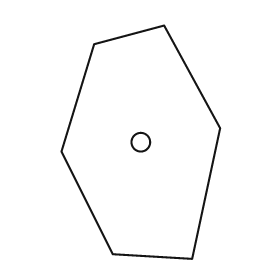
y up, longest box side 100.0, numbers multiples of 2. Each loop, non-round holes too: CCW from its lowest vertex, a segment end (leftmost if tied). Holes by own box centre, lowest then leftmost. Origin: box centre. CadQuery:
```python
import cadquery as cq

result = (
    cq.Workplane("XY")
    .moveTo(22.0, -50.0)
    .lineTo(34.0, 6.0)
    .lineTo(10.0, 50.0)
    .lineTo(-20.0, 42.0)
    .lineTo(-34.0, -4.0)
    .lineTo(-12.0, -48.0)
    .close()
    .moveTo(0.0, 0.0)
    .circle(4.0)
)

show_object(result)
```